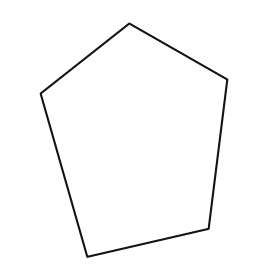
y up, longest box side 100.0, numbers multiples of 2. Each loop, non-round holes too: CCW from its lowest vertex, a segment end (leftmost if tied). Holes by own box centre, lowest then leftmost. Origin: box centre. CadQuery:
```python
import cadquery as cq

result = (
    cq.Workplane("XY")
    .moveTo(-20.0, -50.0)
    .lineTo(32.0, -38.0)
    .lineTo(40.0, 26.0)
    .lineTo(-2.0, 50.0)
    .lineTo(-40.0, 20.0)
    .close()
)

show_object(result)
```